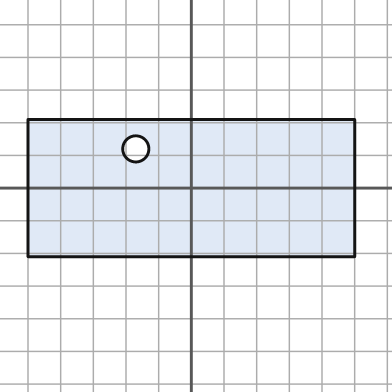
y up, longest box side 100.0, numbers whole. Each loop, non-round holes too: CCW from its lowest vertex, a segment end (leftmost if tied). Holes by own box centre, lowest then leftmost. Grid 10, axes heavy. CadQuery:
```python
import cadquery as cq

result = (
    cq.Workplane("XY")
    .moveTo(-50.0, -21.0)
    .lineTo(50.0, -21.0)
    .lineTo(50.0, 21.0)
    .lineTo(-50.0, 21.0)
    .close()
    .moveTo(-17.0, 12.0)
    .circle(4.0)
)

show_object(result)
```